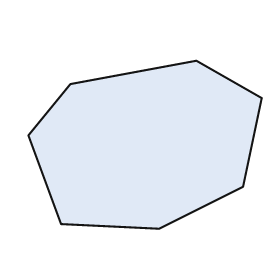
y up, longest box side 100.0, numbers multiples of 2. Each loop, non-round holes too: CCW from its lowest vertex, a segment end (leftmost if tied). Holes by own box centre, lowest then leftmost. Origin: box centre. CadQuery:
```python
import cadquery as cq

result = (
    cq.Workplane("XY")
    .moveTo(6.0, -36.0)
    .lineTo(42.0, -18.0)
    .lineTo(50.0, 20.0)
    .lineTo(22.0, 36.0)
    .lineTo(-32.0, 26.0)
    .lineTo(-50.0, 4.0)
    .lineTo(-36.0, -34.0)
    .close()
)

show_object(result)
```